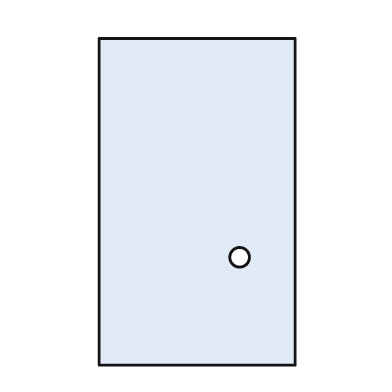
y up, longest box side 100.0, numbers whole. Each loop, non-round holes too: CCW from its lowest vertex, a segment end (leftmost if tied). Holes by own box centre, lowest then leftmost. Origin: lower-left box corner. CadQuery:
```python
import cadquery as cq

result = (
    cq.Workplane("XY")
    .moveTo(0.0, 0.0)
    .lineTo(60.0, 0.0)
    .lineTo(60.0, 100.0)
    .lineTo(0.0, 100.0)
    .close()
    .moveTo(43.0, 33.0)
    .circle(3.0)
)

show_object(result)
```